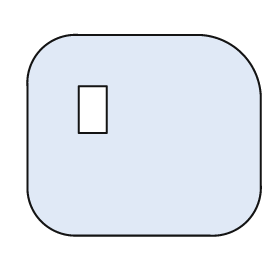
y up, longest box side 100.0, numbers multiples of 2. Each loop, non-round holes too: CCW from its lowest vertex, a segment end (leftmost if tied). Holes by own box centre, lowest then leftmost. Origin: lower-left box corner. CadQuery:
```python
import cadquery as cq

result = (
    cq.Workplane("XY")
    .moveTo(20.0, 0.0)
    .lineTo(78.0, 0.0)
    .threePointArc((94.0, 6.0), (100.0, 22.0))
    .lineTo(100.0, 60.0)
    .threePointArc((92.0, 78.0), (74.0, 86.0))
    .lineTo(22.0, 86.0)
    .threePointArc((6.0, 80.0), (0.0, 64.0))
    .lineTo(0.0, 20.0)
    .threePointArc((6.0, 6.0), (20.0, 0.0))
    .close()
    .moveTo(22.0, 44.0)
    .lineTo(34.0, 44.0)
    .lineTo(34.0, 64.0)
    .lineTo(22.0, 64.0)
    .close()
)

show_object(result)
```